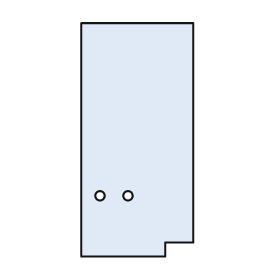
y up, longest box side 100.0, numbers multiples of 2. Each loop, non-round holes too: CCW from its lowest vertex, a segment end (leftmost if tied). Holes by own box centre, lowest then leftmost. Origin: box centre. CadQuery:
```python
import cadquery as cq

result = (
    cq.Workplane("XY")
    .moveTo(-24.0, -50.0)
    .lineTo(12.0, -50.0)
    .lineTo(12.0, -44.0)
    .lineTo(24.0, -44.0)
    .lineTo(24.0, 50.0)
    .lineTo(-24.0, 50.0)
    .close()
    .moveTo(-16.0, -24.0)
    .circle(2.0)
    .moveTo(-4.0, -24.0)
    .circle(2.0)
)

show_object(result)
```